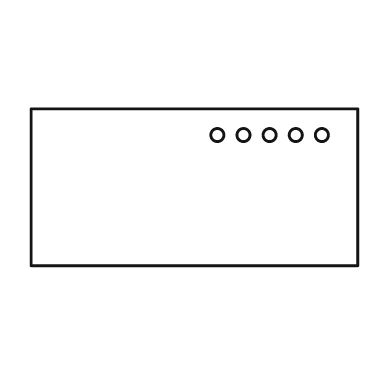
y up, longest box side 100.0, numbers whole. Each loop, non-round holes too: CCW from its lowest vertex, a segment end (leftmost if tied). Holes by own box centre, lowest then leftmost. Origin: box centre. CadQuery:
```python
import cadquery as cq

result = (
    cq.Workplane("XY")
    .moveTo(-50.0, -24.0)
    .lineTo(50.0, -24.0)
    .lineTo(50.0, 24.0)
    .lineTo(-50.0, 24.0)
    .close()
    .moveTo(7.0, 16.0)
    .circle(2.0)
    .moveTo(15.0, 16.0)
    .circle(2.0)
    .moveTo(23.0, 16.0)
    .circle(2.0)
    .moveTo(31.0, 16.0)
    .circle(2.0)
    .moveTo(39.0, 16.0)
    .circle(2.0)
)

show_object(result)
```